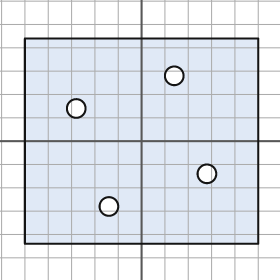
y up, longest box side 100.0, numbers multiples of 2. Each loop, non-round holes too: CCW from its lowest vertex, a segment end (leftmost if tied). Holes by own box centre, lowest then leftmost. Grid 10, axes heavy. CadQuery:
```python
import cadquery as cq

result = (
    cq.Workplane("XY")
    .moveTo(-50.0, -44.0)
    .lineTo(50.0, -44.0)
    .lineTo(50.0, 44.0)
    .lineTo(-50.0, 44.0)
    .close()
    .moveTo(-14.0, -28.0)
    .circle(4.0)
    .moveTo(28.0, -14.0)
    .circle(4.0)
    .moveTo(-28.0, 14.0)
    .circle(4.0)
    .moveTo(14.0, 28.0)
    .circle(4.0)
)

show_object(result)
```